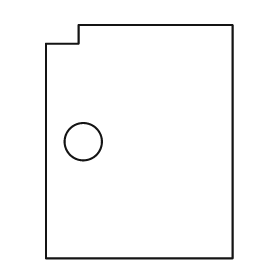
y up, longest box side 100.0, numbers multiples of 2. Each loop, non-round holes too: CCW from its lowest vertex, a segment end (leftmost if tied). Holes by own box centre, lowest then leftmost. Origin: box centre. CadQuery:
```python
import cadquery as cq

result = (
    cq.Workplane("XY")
    .moveTo(-40.0, -50.0)
    .lineTo(40.0, -50.0)
    .lineTo(40.0, 50.0)
    .lineTo(-26.0, 50.0)
    .lineTo(-26.0, 42.0)
    .lineTo(-40.0, 42.0)
    .close()
    .moveTo(-24.0, 0.0)
    .circle(8.0)
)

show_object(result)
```